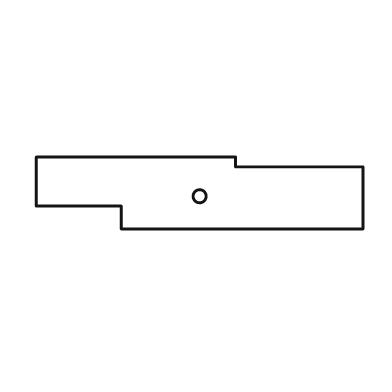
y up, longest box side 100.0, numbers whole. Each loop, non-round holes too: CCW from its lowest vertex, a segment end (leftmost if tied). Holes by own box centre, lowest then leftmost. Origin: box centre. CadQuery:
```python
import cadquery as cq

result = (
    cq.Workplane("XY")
    .moveTo(-24.0, -11.0)
    .lineTo(50.0, -11.0)
    .lineTo(50.0, 8.0)
    .lineTo(11.0, 8.0)
    .lineTo(11.0, 11.0)
    .lineTo(-50.0, 11.0)
    .lineTo(-50.0, -4.0)
    .lineTo(-24.0, -4.0)
    .close()
    .moveTo(0.0, -1.0)
    .circle(2.0)
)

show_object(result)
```